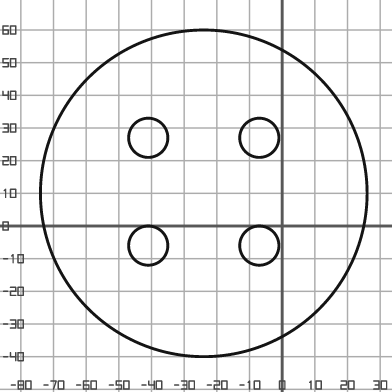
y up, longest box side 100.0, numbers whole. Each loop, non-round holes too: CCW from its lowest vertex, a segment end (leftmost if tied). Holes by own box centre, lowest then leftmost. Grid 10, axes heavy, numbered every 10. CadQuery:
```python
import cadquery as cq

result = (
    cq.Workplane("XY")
    .moveTo(-24.0, 10.0)
    .circle(50.0)
    .moveTo(-41.0, -6.0)
    .circle(6.0)
    .moveTo(-7.0, -6.0)
    .circle(6.0)
    .moveTo(-41.0, 27.0)
    .circle(6.0)
    .moveTo(-7.0, 27.0)
    .circle(6.0)
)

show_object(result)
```